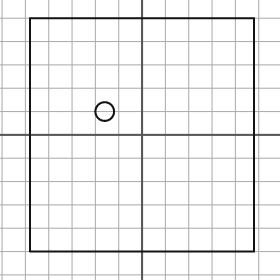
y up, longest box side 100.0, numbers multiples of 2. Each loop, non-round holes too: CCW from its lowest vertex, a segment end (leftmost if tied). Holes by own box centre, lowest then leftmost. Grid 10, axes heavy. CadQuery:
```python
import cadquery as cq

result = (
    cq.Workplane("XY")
    .moveTo(-48.0, -50.0)
    .lineTo(48.0, -50.0)
    .lineTo(48.0, 50.0)
    .lineTo(-48.0, 50.0)
    .close()
    .moveTo(-16.0, 10.0)
    .circle(4.0)
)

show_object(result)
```